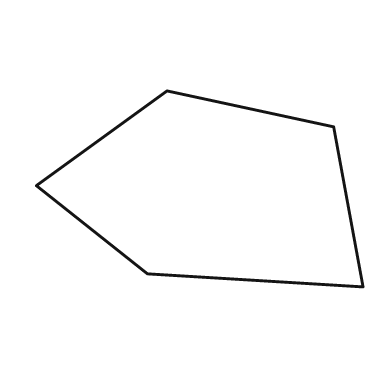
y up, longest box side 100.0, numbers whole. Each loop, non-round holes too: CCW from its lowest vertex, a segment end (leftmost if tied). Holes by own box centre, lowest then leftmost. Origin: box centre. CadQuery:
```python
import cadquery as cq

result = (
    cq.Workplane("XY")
    .moveTo(50.0, -30.0)
    .lineTo(41.0, 19.0)
    .lineTo(-10.0, 30.0)
    .lineTo(-50.0, 1.0)
    .lineTo(-16.0, -26.0)
    .close()
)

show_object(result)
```